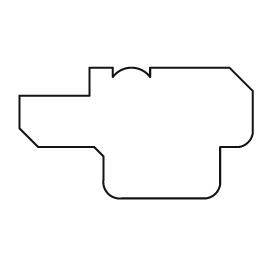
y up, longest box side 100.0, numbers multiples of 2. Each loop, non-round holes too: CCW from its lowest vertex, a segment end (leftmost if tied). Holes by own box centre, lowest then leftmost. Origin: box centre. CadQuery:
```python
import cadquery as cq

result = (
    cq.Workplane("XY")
    .moveTo(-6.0, -28.0)
    .lineTo(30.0, -28.0)
    .threePointArc((34.0, -26.0), (36.0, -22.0))
    .lineTo(36.0, -6.0)
    .lineTo(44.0, -6.0)
    .threePointArc((48.0, -4.0), (50.0, 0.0))
    .lineTo(50.0, 18.0)
    .lineTo(40.0, 28.0)
    .lineTo(6.0, 28.0)
    .lineTo(6.0, 24.0)
    .threePointArc((-2.0, 28.0), (-10.0, 24.0))
    .lineTo(-10.0, 28.0)
    .lineTo(-20.0, 28.0)
    .lineTo(-20.0, 16.0)
    .lineTo(-50.0, 16.0)
    .lineTo(-50.0, 2.0)
    .lineTo(-42.0, -6.0)
    .lineTo(-18.0, -6.0)
    .lineTo(-14.0, -10.0)
    .lineTo(-14.0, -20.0)
    .threePointArc((-12.0, -26.0), (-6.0, -28.0))
    .close()
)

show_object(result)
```